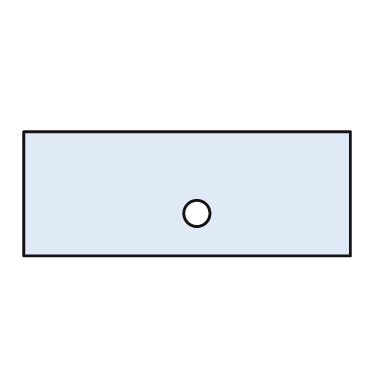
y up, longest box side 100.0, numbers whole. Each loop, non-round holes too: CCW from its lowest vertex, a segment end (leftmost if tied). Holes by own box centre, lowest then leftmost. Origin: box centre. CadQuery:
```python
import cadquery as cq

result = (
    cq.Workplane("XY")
    .moveTo(-50.0, -19.0)
    .lineTo(50.0, -19.0)
    .lineTo(50.0, 19.0)
    .lineTo(-50.0, 19.0)
    .close()
    .moveTo(3.0, -6.0)
    .circle(4.0)
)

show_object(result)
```